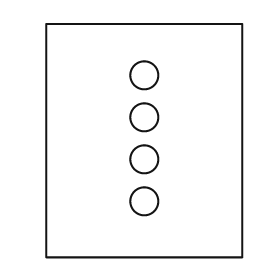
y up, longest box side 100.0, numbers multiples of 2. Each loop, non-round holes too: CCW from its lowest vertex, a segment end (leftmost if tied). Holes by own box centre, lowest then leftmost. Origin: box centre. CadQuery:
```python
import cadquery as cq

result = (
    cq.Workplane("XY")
    .moveTo(-42.0, -50.0)
    .lineTo(42.0, -50.0)
    .lineTo(42.0, 50.0)
    .lineTo(-42.0, 50.0)
    .close()
    .moveTo(0.0, -26.0)
    .circle(6.0)
    .moveTo(0.0, -8.0)
    .circle(6.0)
    .moveTo(0.0, 10.0)
    .circle(6.0)
    .moveTo(0.0, 28.0)
    .circle(6.0)
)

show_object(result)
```